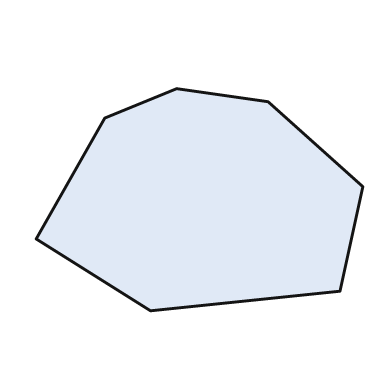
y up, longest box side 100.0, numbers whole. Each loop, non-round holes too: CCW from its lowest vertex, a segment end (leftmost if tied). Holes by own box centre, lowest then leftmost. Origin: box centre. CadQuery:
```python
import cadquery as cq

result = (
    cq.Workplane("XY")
    .moveTo(-15.0, -34.0)
    .lineTo(43.0, -28.0)
    .lineTo(50.0, 4.0)
    .lineTo(21.0, 30.0)
    .lineTo(-7.0, 34.0)
    .lineTo(-29.0, 25.0)
    .lineTo(-50.0, -12.0)
    .close()
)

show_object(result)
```